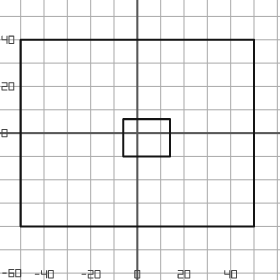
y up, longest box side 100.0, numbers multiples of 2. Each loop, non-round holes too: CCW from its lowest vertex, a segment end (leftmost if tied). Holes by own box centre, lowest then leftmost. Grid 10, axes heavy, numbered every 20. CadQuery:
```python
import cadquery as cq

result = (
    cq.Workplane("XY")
    .moveTo(-50.0, -40.0)
    .lineTo(50.0, -40.0)
    .lineTo(50.0, 40.0)
    .lineTo(-50.0, 40.0)
    .close()
    .moveTo(-6.0, -10.0)
    .lineTo(14.0, -10.0)
    .lineTo(14.0, 6.0)
    .lineTo(-6.0, 6.0)
    .close()
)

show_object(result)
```